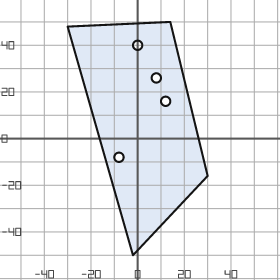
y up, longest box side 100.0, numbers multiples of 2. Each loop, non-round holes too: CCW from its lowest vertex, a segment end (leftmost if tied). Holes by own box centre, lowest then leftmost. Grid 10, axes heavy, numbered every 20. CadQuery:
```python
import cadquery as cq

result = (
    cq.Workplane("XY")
    .moveTo(-2.0, -50.0)
    .lineTo(30.0, -16.0)
    .lineTo(14.0, 50.0)
    .lineTo(-30.0, 48.0)
    .close()
    .moveTo(-8.0, -8.0)
    .circle(2.0)
    .moveTo(12.0, 16.0)
    .circle(2.0)
    .moveTo(8.0, 26.0)
    .circle(2.0)
    .moveTo(0.0, 40.0)
    .circle(2.0)
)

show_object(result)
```